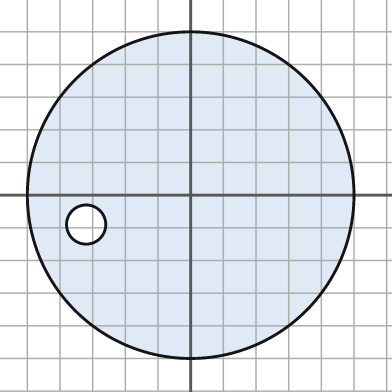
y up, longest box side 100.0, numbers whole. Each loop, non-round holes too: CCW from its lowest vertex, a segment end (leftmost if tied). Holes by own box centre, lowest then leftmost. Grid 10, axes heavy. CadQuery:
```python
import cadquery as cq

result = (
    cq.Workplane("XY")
    .moveTo(0.0, 0.0)
    .circle(50.0)
    .moveTo(-32.0, -9.0)
    .circle(6.0)
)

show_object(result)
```